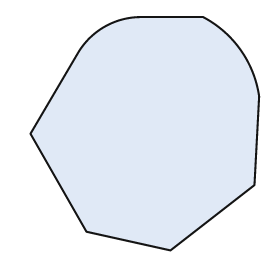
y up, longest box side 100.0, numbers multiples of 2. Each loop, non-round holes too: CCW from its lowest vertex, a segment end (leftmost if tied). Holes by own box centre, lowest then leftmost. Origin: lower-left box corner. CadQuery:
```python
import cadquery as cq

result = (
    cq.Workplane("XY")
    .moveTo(60.0, 0.0)
    .lineTo(96.0, 28.0)
    .lineTo(98.0, 66.0)
    .threePointArc((90.0, 86.0), (74.0, 100.0))
    .lineTo(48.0, 100.0)
    .threePointArc((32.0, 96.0), (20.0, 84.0))
    .lineTo(0.0, 50.0)
    .lineTo(24.0, 8.0)
    .close()
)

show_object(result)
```